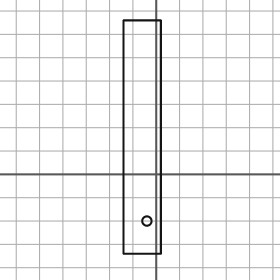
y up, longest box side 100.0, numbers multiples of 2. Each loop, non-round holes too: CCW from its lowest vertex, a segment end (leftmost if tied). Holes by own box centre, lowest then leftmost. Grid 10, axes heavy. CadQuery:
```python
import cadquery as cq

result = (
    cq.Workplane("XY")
    .moveTo(-14.0, -34.0)
    .lineTo(2.0, -34.0)
    .lineTo(2.0, 66.0)
    .lineTo(-14.0, 66.0)
    .close()
    .moveTo(-4.0, -20.0)
    .circle(2.0)
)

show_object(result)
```